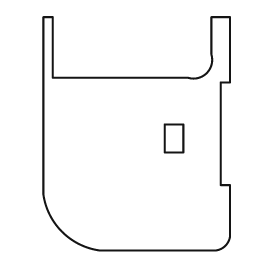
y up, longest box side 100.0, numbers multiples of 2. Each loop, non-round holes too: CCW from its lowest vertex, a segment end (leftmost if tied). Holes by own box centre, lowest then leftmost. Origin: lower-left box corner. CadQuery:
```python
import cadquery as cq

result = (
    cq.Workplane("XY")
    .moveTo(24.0, 0.0)
    .lineTo(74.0, 0.0)
    .threePointArc((78.0, 2.0), (80.0, 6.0))
    .lineTo(80.0, 28.0)
    .lineTo(76.0, 28.0)
    .lineTo(76.0, 72.0)
    .lineTo(80.0, 72.0)
    .lineTo(80.0, 100.0)
    .lineTo(72.0, 100.0)
    .lineTo(72.0, 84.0)
    .threePointArc((70.0, 76.0), (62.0, 74.0))
    .lineTo(4.0, 74.0)
    .lineTo(4.0, 100.0)
    .lineTo(0.0, 100.0)
    .lineTo(0.0, 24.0)
    .threePointArc((8.0, 8.0), (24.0, 0.0))
    .close()
    .moveTo(52.0, 42.0)
    .lineTo(60.0, 42.0)
    .lineTo(60.0, 54.0)
    .lineTo(52.0, 54.0)
    .close()
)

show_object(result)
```